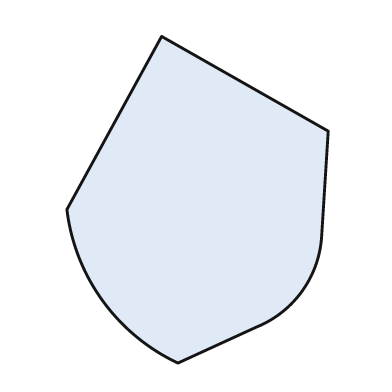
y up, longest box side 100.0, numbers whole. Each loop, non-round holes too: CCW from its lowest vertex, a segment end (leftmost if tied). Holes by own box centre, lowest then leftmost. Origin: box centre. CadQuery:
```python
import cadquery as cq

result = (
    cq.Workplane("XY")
    .moveTo(-6.0, -50.0)
    .lineTo(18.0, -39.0)
    .threePointArc((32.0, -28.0), (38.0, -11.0))
    .lineTo(40.0, 21.0)
    .lineTo(-11.0, 50.0)
    .lineTo(-40.0, -3.0)
    .threePointArc((-29.0, -31.0), (-6.0, -50.0))
    .close()
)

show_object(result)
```